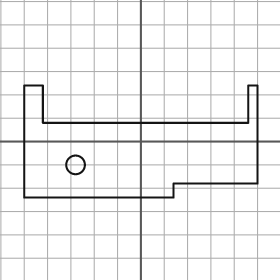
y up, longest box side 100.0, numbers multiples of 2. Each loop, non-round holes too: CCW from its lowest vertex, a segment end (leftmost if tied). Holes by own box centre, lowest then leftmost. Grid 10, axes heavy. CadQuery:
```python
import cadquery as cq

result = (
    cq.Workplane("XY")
    .moveTo(-50.0, -24.0)
    .lineTo(14.0, -24.0)
    .lineTo(14.0, -18.0)
    .lineTo(50.0, -18.0)
    .lineTo(50.0, 24.0)
    .lineTo(46.0, 24.0)
    .lineTo(46.0, 8.0)
    .lineTo(-42.0, 8.0)
    .lineTo(-42.0, 24.0)
    .lineTo(-50.0, 24.0)
    .close()
    .moveTo(-28.0, -10.0)
    .circle(4.0)
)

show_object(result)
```